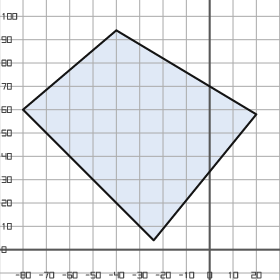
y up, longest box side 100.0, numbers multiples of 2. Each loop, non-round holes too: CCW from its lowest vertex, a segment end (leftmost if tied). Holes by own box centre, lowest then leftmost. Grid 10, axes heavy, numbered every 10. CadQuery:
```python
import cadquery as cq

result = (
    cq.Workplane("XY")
    .moveTo(-24.0, 4.0)
    .lineTo(20.0, 58.0)
    .lineTo(-40.0, 94.0)
    .lineTo(-80.0, 60.0)
    .close()
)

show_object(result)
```